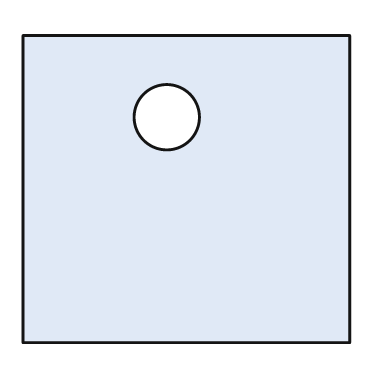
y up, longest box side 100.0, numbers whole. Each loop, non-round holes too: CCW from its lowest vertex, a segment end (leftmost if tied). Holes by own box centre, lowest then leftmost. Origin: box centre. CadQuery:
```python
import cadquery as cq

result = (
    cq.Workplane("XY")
    .moveTo(-50.0, -47.0)
    .lineTo(50.0, -47.0)
    .lineTo(50.0, 47.0)
    .lineTo(-50.0, 47.0)
    .close()
    .moveTo(-6.0, 22.0)
    .circle(10.0)
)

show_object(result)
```